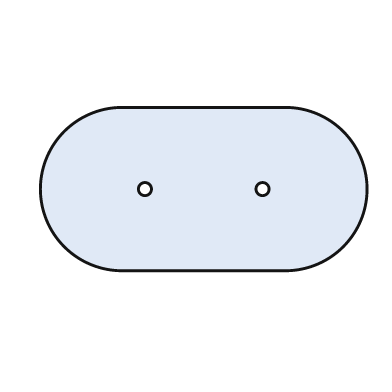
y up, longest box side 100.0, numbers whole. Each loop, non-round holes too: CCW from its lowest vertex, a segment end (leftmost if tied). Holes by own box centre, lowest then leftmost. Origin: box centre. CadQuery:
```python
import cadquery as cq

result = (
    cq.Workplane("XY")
    .moveTo(-25.0, -25.0)
    .lineTo(25.0, -25.0)
    .threePointArc((50.0, 0.0), (25.0, 25.0))
    .lineTo(-25.0, 25.0)
    .threePointArc((-50.0, 0.0), (-25.0, -25.0))
    .close()
    .moveTo(-18.0, 0.0)
    .circle(2.0)
    .moveTo(18.0, 0.0)
    .circle(2.0)
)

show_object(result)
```